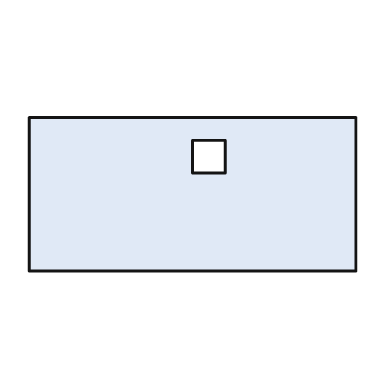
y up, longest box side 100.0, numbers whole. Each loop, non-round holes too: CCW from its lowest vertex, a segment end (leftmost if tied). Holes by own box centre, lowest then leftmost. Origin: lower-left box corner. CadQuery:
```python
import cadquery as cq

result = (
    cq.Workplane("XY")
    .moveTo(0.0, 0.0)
    .lineTo(100.0, 0.0)
    .lineTo(100.0, 47.0)
    .lineTo(0.0, 47.0)
    .close()
    .moveTo(50.0, 30.0)
    .lineTo(60.0, 30.0)
    .lineTo(60.0, 40.0)
    .lineTo(50.0, 40.0)
    .close()
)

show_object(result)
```